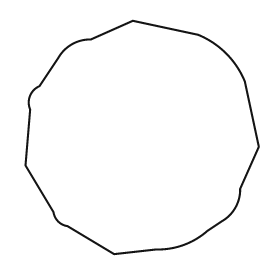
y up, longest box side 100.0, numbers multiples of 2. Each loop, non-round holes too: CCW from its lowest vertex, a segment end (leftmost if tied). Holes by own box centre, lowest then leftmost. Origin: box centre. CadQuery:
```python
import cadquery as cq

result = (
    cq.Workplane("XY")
    .moveTo(-12.0, -50.0)
    .lineTo(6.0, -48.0)
    .threePointArc((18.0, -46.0), (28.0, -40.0))
    .lineTo(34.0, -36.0)
    .threePointArc((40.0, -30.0), (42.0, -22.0))
    .lineTo(50.0, -4.0)
    .lineTo(44.0, 24.0)
    .threePointArc((36.0, 36.0), (24.0, 44.0))
    .lineTo(-4.0, 50.0)
    .lineTo(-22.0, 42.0)
    .threePointArc((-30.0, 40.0), (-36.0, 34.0))
    .lineTo(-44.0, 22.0)
    .threePointArc((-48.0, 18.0), (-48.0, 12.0))
    .lineTo(-50.0, -12.0)
    .lineTo(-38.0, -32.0)
    .threePointArc((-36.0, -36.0), (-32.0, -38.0))
    .close()
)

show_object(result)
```